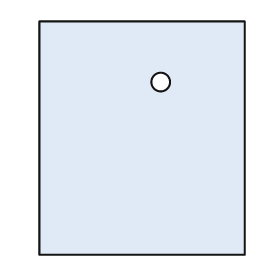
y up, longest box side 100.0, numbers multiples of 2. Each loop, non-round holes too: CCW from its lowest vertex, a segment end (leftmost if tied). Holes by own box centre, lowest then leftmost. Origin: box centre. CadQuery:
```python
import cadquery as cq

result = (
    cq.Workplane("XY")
    .moveTo(-44.0, -50.0)
    .lineTo(44.0, -50.0)
    .lineTo(44.0, 50.0)
    .lineTo(-44.0, 50.0)
    .close()
    .moveTo(8.0, 24.0)
    .circle(4.0)
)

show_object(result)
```